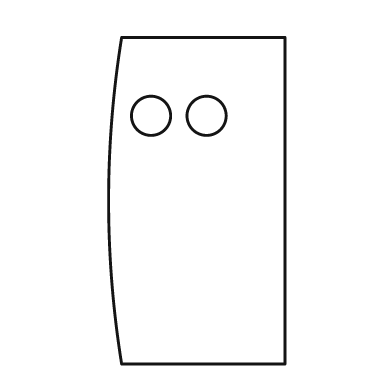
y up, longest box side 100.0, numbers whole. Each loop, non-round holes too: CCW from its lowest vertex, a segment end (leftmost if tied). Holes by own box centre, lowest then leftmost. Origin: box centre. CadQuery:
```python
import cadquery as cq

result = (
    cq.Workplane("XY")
    .moveTo(-23.0, -50.0)
    .lineTo(27.0, -50.0)
    .lineTo(27.0, 50.0)
    .lineTo(-23.0, 50.0)
    .threePointArc((-27.0, 0.0), (-23.0, -50.0))
    .close()
    .moveTo(-14.0, 26.0)
    .circle(6.0)
    .moveTo(3.0, 26.0)
    .circle(6.0)
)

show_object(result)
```